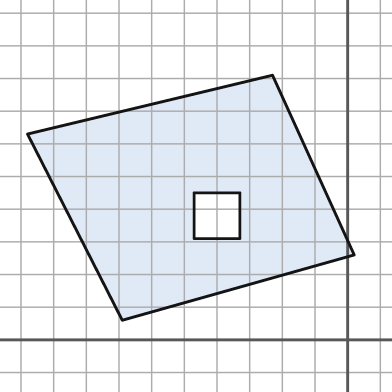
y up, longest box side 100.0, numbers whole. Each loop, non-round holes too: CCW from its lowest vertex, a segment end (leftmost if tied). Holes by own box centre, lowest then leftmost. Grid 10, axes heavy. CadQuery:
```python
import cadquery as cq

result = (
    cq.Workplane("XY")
    .moveTo(-69.0, 6.0)
    .lineTo(2.0, 26.0)
    .lineTo(-23.0, 81.0)
    .lineTo(-98.0, 63.0)
    .close()
    .moveTo(-47.0, 31.0)
    .lineTo(-33.0, 31.0)
    .lineTo(-33.0, 45.0)
    .lineTo(-47.0, 45.0)
    .close()
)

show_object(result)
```